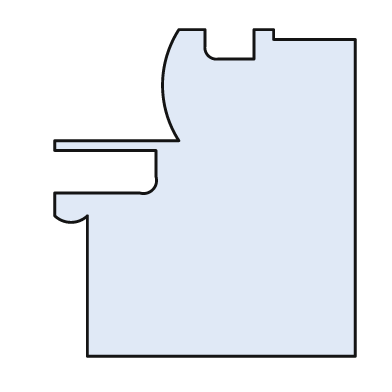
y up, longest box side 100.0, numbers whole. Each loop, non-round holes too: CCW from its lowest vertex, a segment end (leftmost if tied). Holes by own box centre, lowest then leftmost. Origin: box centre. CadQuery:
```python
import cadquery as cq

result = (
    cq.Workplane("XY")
    .moveTo(-36.0, -50.0)
    .lineTo(46.0, -50.0)
    .lineTo(46.0, 47.0)
    .lineTo(21.0, 47.0)
    .lineTo(21.0, 50.0)
    .lineTo(15.0, 50.0)
    .lineTo(15.0, 41.0)
    .lineTo(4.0, 41.0)
    .threePointArc((1.0, 42.0), (0.0, 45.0))
    .lineTo(0.0, 50.0)
    .lineTo(-8.0, 50.0)
    .threePointArc((-13.0, 33.0), (-8.0, 16.0))
    .lineTo(-46.0, 16.0)
    .lineTo(-46.0, 13.0)
    .lineTo(-15.0, 13.0)
    .lineTo(-15.0, 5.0)
    .threePointArc((-16.0, 1.0), (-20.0, 0.0))
    .lineTo(-46.0, 0.0)
    .lineTo(-46.0, -7.0)
    .threePointArc((-41.0, -9.0), (-36.0, -7.0))
    .close()
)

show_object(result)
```